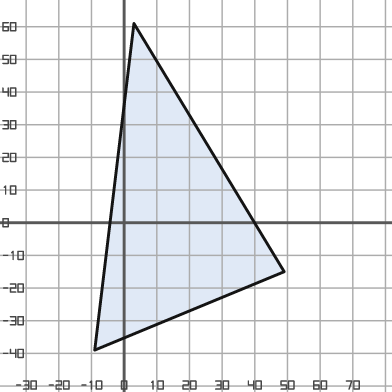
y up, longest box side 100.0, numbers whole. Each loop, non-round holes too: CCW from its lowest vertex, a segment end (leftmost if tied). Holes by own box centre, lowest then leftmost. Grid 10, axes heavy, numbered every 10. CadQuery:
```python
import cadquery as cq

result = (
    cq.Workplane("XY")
    .moveTo(-9.0, -39.0)
    .lineTo(49.0, -15.0)
    .lineTo(3.0, 61.0)
    .close()
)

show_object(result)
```